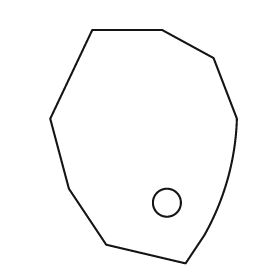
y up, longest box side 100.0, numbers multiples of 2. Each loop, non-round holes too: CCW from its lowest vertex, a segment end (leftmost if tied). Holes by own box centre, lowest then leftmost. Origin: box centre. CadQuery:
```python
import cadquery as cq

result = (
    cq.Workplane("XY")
    .moveTo(18.0, -50.0)
    .lineTo(26.0, -38.0)
    .threePointArc((36.0, -14.0), (40.0, 12.0))
    .lineTo(30.0, 38.0)
    .lineTo(8.0, 50.0)
    .lineTo(-22.0, 50.0)
    .lineTo(-40.0, 12.0)
    .lineTo(-32.0, -18.0)
    .lineTo(-16.0, -42.0)
    .close()
    .moveTo(10.0, -24.0)
    .circle(6.0)
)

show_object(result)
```